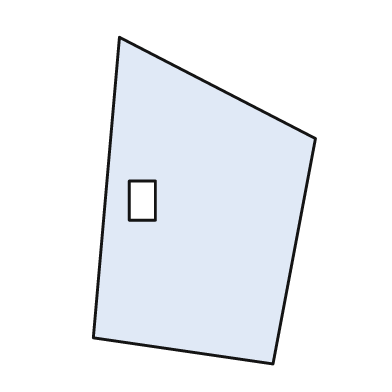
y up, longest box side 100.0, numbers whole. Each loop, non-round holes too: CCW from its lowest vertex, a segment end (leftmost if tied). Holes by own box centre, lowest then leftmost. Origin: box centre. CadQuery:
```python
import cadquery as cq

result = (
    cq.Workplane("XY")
    .moveTo(21.0, -50.0)
    .lineTo(34.0, 19.0)
    .lineTo(-26.0, 50.0)
    .lineTo(-34.0, -42.0)
    .close()
    .moveTo(-23.0, -6.0)
    .lineTo(-15.0, -6.0)
    .lineTo(-15.0, 6.0)
    .lineTo(-23.0, 6.0)
    .close()
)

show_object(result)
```